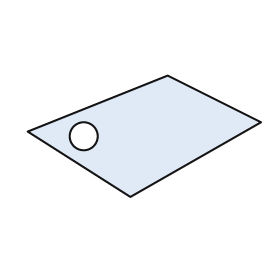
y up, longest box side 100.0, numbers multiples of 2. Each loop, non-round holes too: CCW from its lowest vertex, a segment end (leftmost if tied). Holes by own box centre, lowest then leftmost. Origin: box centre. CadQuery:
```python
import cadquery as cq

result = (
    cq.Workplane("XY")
    .moveTo(-6.0, -26.0)
    .lineTo(50.0, 6.0)
    .lineTo(10.0, 26.0)
    .lineTo(-50.0, 2.0)
    .close()
    .moveTo(-26.0, 0.0)
    .circle(6.0)
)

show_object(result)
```